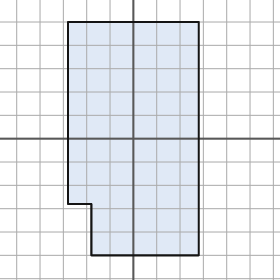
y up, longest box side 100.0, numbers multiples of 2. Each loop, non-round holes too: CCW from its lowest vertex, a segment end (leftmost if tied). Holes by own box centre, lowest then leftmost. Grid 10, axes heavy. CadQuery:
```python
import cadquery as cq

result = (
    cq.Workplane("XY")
    .moveTo(-18.0, -50.0)
    .lineTo(28.0, -50.0)
    .lineTo(28.0, 50.0)
    .lineTo(-28.0, 50.0)
    .lineTo(-28.0, -28.0)
    .lineTo(-18.0, -28.0)
    .close()
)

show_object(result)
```